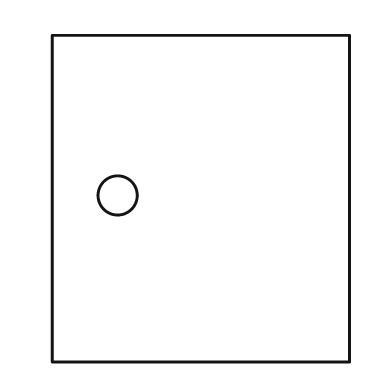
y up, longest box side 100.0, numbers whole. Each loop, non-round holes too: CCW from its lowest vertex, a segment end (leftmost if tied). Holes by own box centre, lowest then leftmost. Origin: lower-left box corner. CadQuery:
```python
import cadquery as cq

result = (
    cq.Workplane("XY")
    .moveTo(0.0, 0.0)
    .lineTo(91.0, 0.0)
    .lineTo(91.0, 100.0)
    .lineTo(0.0, 100.0)
    .close()
    .moveTo(20.0, 51.0)
    .circle(6.0)
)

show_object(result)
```